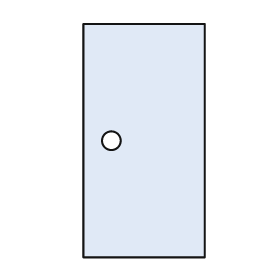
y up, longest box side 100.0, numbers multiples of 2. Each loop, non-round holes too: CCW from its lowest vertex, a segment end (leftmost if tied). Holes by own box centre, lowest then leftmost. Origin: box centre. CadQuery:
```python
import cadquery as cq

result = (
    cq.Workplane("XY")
    .moveTo(-26.0, -50.0)
    .lineTo(26.0, -50.0)
    .lineTo(26.0, 50.0)
    .lineTo(-26.0, 50.0)
    .close()
    .moveTo(-14.0, 0.0)
    .circle(4.0)
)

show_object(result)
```